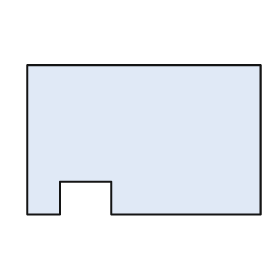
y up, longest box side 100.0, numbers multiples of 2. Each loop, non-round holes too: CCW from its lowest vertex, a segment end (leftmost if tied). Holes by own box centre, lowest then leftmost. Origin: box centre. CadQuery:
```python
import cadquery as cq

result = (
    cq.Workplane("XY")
    .moveTo(-50.0, -32.0)
    .lineTo(-36.0, -32.0)
    .lineTo(-36.0, -18.0)
    .lineTo(-14.0, -18.0)
    .lineTo(-14.0, -32.0)
    .lineTo(50.0, -32.0)
    .lineTo(50.0, 32.0)
    .lineTo(-50.0, 32.0)
    .close()
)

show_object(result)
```